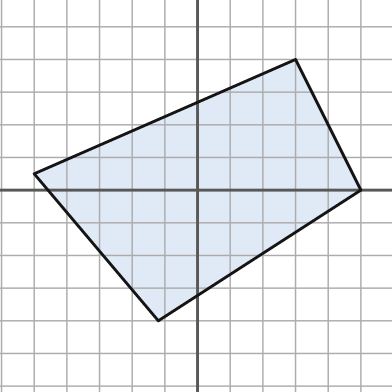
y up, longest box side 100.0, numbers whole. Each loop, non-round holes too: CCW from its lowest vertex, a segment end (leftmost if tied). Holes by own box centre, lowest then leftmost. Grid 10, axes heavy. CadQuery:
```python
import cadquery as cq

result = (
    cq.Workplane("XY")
    .moveTo(-12.0, -40.0)
    .lineTo(50.0, 0.0)
    .lineTo(30.0, 40.0)
    .lineTo(-50.0, 5.0)
    .close()
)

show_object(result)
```